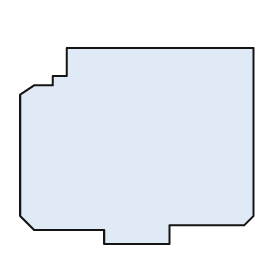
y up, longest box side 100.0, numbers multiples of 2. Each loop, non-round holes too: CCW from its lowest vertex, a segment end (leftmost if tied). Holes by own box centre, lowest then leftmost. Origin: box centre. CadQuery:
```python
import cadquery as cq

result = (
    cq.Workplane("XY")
    .moveTo(-14.0, -42.0)
    .lineTo(14.0, -42.0)
    .lineTo(14.0, -34.0)
    .lineTo(46.0, -34.0)
    .lineTo(50.0, -30.0)
    .lineTo(50.0, 42.0)
    .lineTo(-30.0, 42.0)
    .lineTo(-30.0, 30.0)
    .lineTo(-36.0, 30.0)
    .lineTo(-36.0, 26.0)
    .lineTo(-44.0, 26.0)
    .lineTo(-50.0, 22.0)
    .lineTo(-50.0, -30.0)
    .lineTo(-44.0, -36.0)
    .lineTo(-14.0, -36.0)
    .close()
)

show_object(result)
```